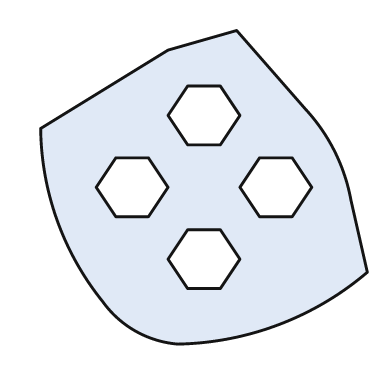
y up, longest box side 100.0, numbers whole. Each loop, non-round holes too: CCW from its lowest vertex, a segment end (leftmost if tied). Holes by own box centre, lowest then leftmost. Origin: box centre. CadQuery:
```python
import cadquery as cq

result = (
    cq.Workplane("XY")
    .moveTo(-8.0, -48.0)
    .threePointArc((23.0, -42.0), (50.0, -26.0))
    .lineTo(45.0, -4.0)
    .threePointArc((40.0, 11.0), (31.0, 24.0))
    .lineTo(10.0, 48.0)
    .lineTo(-11.0, 42.0)
    .lineTo(-50.0, 18.0)
    .threePointArc((-45.0, -10.0), (-31.0, -35.0))
    .threePointArc((-21.0, -44.0), (-8.0, -48.0))
    .close()
    .moveTo(-5.0, -31.0)
    .lineTo(5.0, -31.0)
    .lineTo(11.0, -22.0)
    .lineTo(5.0, -13.0)
    .lineTo(-5.0, -13.0)
    .lineTo(-11.0, -22.0)
    .close()
    .moveTo(-27.0, -9.0)
    .lineTo(-17.0, -9.0)
    .lineTo(-11.0, 0.0)
    .lineTo(-17.0, 9.0)
    .lineTo(-27.0, 9.0)
    .lineTo(-33.0, 0.0)
    .close()
    .moveTo(17.0, -9.0)
    .lineTo(27.0, -9.0)
    .lineTo(33.0, 0.0)
    .lineTo(27.0, 9.0)
    .lineTo(17.0, 9.0)
    .lineTo(11.0, 0.0)
    .close()
    .moveTo(-5.0, 13.0)
    .lineTo(5.0, 13.0)
    .lineTo(11.0, 22.0)
    .lineTo(5.0, 31.0)
    .lineTo(-5.0, 31.0)
    .lineTo(-11.0, 22.0)
    .close()
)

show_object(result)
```